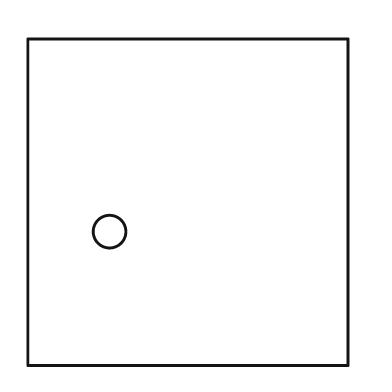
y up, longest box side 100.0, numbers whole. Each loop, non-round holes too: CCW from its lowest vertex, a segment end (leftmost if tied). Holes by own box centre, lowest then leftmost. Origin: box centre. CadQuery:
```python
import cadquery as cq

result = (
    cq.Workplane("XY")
    .moveTo(-49.0, -50.0)
    .lineTo(49.0, -50.0)
    .lineTo(49.0, 50.0)
    .lineTo(-49.0, 50.0)
    .close()
    .moveTo(-24.0, -9.0)
    .circle(5.0)
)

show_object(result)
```